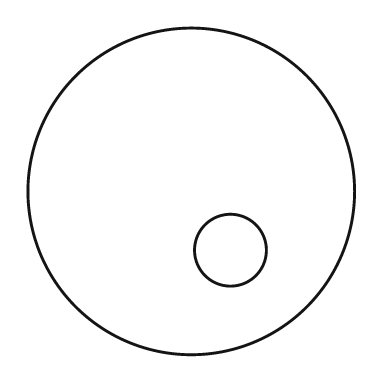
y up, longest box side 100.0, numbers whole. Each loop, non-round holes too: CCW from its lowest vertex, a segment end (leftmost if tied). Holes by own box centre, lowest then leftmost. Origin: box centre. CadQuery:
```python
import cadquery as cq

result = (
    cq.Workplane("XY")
    .moveTo(0.0, 0.0)
    .circle(50.0)
    .moveTo(12.0, -18.0)
    .circle(11.0)
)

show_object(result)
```